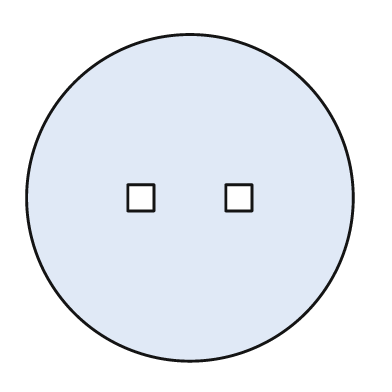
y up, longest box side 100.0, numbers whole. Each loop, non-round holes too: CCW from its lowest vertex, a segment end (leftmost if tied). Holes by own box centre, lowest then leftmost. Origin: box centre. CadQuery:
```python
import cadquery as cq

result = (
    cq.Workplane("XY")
    .moveTo(0.0, 0.0)
    .circle(50.0)
    .moveTo(-19.0, -4.0)
    .lineTo(-11.0, -4.0)
    .lineTo(-11.0, 4.0)
    .lineTo(-19.0, 4.0)
    .close()
    .moveTo(11.0, -4.0)
    .lineTo(19.0, -4.0)
    .lineTo(19.0, 4.0)
    .lineTo(11.0, 4.0)
    .close()
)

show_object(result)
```